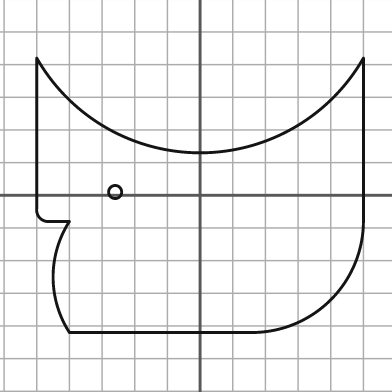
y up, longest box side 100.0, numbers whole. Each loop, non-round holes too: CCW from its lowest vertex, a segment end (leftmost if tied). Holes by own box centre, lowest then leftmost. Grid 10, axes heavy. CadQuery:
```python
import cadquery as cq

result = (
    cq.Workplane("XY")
    .moveTo(-40.0, -42.0)
    .lineTo(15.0, -42.0)
    .threePointArc((40.0, -32.0), (50.0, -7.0))
    .lineTo(50.0, 42.0)
    .threePointArc((0.0, 13.0), (-50.0, 42.0))
    .lineTo(-50.0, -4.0)
    .threePointArc((-49.0, -7.0), (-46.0, -8.0))
    .lineTo(-40.0, -8.0)
    .threePointArc((-45.0, -25.0), (-40.0, -42.0))
    .close()
    .moveTo(-26.0, 1.0)
    .circle(2.0)
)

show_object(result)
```